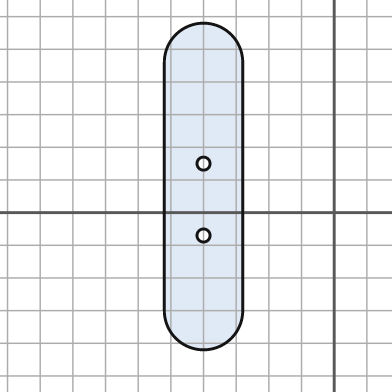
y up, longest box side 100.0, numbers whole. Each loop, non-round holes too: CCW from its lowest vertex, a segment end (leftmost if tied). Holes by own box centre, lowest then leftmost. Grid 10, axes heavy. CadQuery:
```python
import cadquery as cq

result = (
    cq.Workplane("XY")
    .moveTo(-52.0, -30.0)
    .threePointArc((-40.0, -42.0), (-28.0, -30.0))
    .lineTo(-28.0, 46.0)
    .threePointArc((-40.0, 58.0), (-52.0, 46.0))
    .close()
    .moveTo(-40.0, -7.0)
    .circle(2.0)
    .moveTo(-40.0, 15.0)
    .circle(2.0)
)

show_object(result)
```